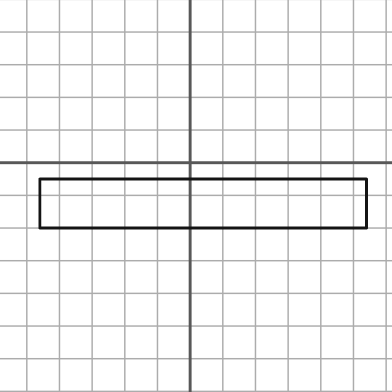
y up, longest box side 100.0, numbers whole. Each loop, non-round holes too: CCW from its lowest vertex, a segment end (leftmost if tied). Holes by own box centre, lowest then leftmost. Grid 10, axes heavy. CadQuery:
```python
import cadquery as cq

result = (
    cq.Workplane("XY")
    .moveTo(-46.0, -20.0)
    .lineTo(54.0, -20.0)
    .lineTo(54.0, -5.0)
    .lineTo(-46.0, -5.0)
    .close()
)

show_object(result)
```